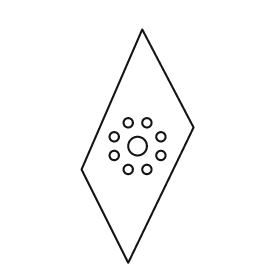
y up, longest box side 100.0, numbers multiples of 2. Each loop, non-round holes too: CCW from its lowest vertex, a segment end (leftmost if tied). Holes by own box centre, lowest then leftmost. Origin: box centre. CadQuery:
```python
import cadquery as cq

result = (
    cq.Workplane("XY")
    .moveTo(-4.0, -50.0)
    .lineTo(24.0, 8.0)
    .lineTo(2.0, 50.0)
    .lineTo(-24.0, -10.0)
    .close()
    .moveTo(-4.0, -10.0)
    .circle(2.0)
    .moveTo(4.0, -10.0)
    .circle(2.0)
    .moveTo(-10.0, -4.0)
    .circle(2.0)
    .moveTo(10.0, -4.0)
    .circle(2.0)
    .moveTo(0.0, 0.0)
    .circle(4.0)
    .moveTo(-10.0, 4.0)
    .circle(2.0)
    .moveTo(10.0, 4.0)
    .circle(2.0)
    .moveTo(-4.0, 10.0)
    .circle(2.0)
    .moveTo(4.0, 10.0)
    .circle(2.0)
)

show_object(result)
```